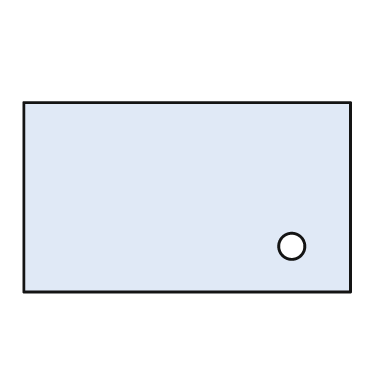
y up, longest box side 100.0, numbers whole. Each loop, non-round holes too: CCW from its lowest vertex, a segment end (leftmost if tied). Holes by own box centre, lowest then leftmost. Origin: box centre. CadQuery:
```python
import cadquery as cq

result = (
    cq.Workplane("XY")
    .moveTo(-50.0, -29.0)
    .lineTo(50.0, -29.0)
    .lineTo(50.0, 29.0)
    .lineTo(-50.0, 29.0)
    .close()
    .moveTo(32.0, -15.0)
    .circle(4.0)
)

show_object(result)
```